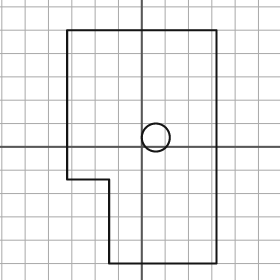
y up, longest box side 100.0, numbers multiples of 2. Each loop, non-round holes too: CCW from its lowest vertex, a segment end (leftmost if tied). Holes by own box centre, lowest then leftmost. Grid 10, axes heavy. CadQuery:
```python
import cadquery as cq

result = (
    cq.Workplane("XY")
    .moveTo(-14.0, -50.0)
    .lineTo(32.0, -50.0)
    .lineTo(32.0, 50.0)
    .lineTo(-32.0, 50.0)
    .lineTo(-32.0, -14.0)
    .lineTo(-14.0, -14.0)
    .close()
    .moveTo(6.0, 4.0)
    .circle(6.0)
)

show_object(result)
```